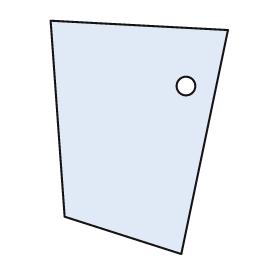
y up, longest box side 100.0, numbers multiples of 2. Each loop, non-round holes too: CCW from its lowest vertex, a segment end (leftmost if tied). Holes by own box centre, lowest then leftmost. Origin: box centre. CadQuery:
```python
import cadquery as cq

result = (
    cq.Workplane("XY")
    .moveTo(18.0, -50.0)
    .lineTo(38.0, 46.0)
    .lineTo(-38.0, 50.0)
    .lineTo(-32.0, -34.0)
    .close()
    .moveTo(20.0, 22.0)
    .circle(4.0)
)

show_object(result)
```